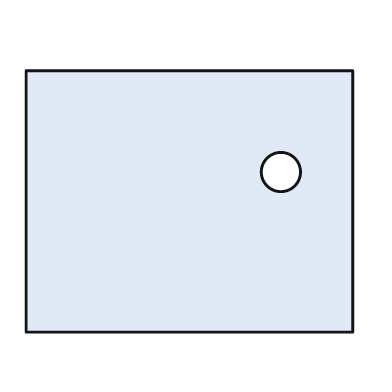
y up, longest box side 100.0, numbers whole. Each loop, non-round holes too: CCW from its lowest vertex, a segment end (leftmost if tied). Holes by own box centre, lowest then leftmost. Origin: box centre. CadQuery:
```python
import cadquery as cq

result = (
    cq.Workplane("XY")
    .moveTo(-50.0, -40.0)
    .lineTo(50.0, -40.0)
    .lineTo(50.0, 40.0)
    .lineTo(-50.0, 40.0)
    .close()
    .moveTo(28.0, 9.0)
    .circle(6.0)
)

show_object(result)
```